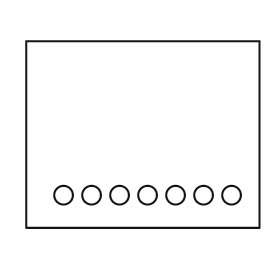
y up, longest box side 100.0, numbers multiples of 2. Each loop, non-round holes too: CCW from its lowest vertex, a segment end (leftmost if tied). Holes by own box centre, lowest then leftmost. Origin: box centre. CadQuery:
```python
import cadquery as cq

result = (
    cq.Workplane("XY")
    .moveTo(-50.0, -40.0)
    .lineTo(50.0, -40.0)
    .lineTo(50.0, 40.0)
    .lineTo(-50.0, 40.0)
    .close()
    .moveTo(-34.0, -26.0)
    .circle(4.0)
    .moveTo(-22.0, -26.0)
    .circle(4.0)
    .moveTo(-10.0, -26.0)
    .circle(4.0)
    .moveTo(2.0, -26.0)
    .circle(4.0)
    .moveTo(14.0, -26.0)
    .circle(4.0)
    .moveTo(26.0, -26.0)
    .circle(4.0)
    .moveTo(38.0, -26.0)
    .circle(4.0)
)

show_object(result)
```